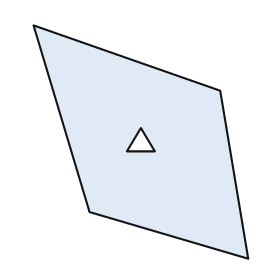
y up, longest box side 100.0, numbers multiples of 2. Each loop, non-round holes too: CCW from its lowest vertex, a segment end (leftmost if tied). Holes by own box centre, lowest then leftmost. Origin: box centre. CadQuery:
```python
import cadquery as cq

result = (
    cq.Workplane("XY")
    .moveTo(46.0, -50.0)
    .lineTo(34.0, 22.0)
    .lineTo(-46.0, 50.0)
    .lineTo(-22.0, -30.0)
    .close()
    .moveTo(-6.0, -4.0)
    .lineTo(6.0, -4.0)
    .lineTo(0.0, 6.0)
    .close()
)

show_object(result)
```